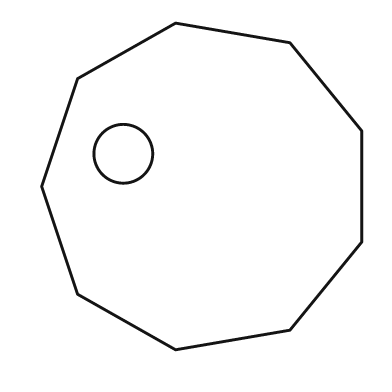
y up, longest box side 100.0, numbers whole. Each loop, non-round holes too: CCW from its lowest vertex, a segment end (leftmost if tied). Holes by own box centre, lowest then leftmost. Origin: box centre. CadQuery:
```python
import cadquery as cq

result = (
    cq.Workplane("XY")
    .moveTo(-8.0, -50.0)
    .lineTo(27.0, -44.0)
    .lineTo(49.0, -17.0)
    .lineTo(49.0, 17.0)
    .lineTo(27.0, 44.0)
    .lineTo(-8.0, 50.0)
    .lineTo(-38.0, 33.0)
    .lineTo(-49.0, 0.0)
    .lineTo(-38.0, -33.0)
    .close()
    .moveTo(-24.0, 10.0)
    .circle(9.0)
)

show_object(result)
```